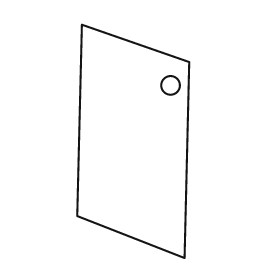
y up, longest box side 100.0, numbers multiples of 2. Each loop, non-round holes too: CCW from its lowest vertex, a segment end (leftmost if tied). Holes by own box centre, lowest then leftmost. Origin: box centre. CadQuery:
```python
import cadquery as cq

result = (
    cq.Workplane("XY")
    .moveTo(22.0, -50.0)
    .lineTo(24.0, 34.0)
    .lineTo(-22.0, 50.0)
    .lineTo(-24.0, -32.0)
    .close()
    .moveTo(16.0, 24.0)
    .circle(4.0)
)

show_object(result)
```